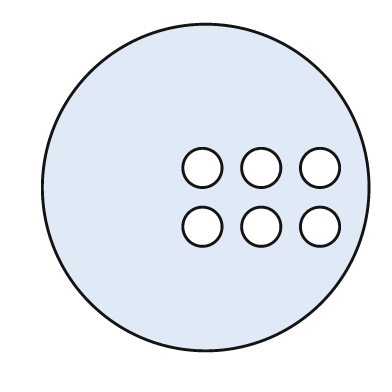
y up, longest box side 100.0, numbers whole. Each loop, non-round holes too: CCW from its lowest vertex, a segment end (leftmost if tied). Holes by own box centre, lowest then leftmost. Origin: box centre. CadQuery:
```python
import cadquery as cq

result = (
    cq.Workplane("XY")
    .moveTo(0.0, 0.0)
    .circle(50.0)
    .moveTo(-1.0, -12.0)
    .circle(6.0)
    .moveTo(17.0, -12.0)
    .circle(6.0)
    .moveTo(35.0, -12.0)
    .circle(6.0)
    .moveTo(-1.0, 6.0)
    .circle(6.0)
    .moveTo(17.0, 6.0)
    .circle(6.0)
    .moveTo(35.0, 6.0)
    .circle(6.0)
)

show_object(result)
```